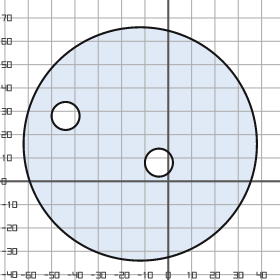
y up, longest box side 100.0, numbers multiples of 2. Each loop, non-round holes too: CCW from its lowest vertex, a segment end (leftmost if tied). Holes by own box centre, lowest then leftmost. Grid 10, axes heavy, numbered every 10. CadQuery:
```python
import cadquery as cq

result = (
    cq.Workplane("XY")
    .moveTo(-12.0, 16.0)
    .circle(50.0)
    .moveTo(-4.0, 8.0)
    .circle(6.0)
    .moveTo(-44.0, 28.0)
    .circle(6.0)
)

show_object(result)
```